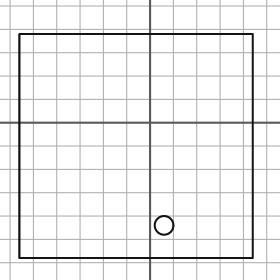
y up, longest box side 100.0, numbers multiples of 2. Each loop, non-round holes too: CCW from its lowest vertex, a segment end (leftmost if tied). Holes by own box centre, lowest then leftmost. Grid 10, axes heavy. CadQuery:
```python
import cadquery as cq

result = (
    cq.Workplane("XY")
    .moveTo(-56.0, -58.0)
    .lineTo(44.0, -58.0)
    .lineTo(44.0, 38.0)
    .lineTo(-56.0, 38.0)
    .close()
    .moveTo(6.0, -44.0)
    .circle(4.0)
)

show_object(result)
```